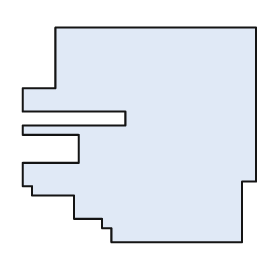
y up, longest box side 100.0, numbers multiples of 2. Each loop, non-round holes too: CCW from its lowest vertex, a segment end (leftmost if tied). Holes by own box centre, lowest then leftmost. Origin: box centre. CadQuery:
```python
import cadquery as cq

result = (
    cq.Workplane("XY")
    .moveTo(-12.0, -46.0)
    .lineTo(44.0, -46.0)
    .lineTo(44.0, -20.0)
    .lineTo(50.0, -20.0)
    .lineTo(50.0, 46.0)
    .lineTo(-36.0, 46.0)
    .lineTo(-36.0, 20.0)
    .lineTo(-50.0, 20.0)
    .lineTo(-50.0, 10.0)
    .lineTo(-6.0, 10.0)
    .lineTo(-6.0, 4.0)
    .lineTo(-50.0, 4.0)
    .lineTo(-50.0, 0.0)
    .lineTo(-26.0, 0.0)
    .lineTo(-26.0, -12.0)
    .lineTo(-50.0, -12.0)
    .lineTo(-50.0, -22.0)
    .lineTo(-46.0, -22.0)
    .lineTo(-46.0, -26.0)
    .lineTo(-28.0, -26.0)
    .lineTo(-28.0, -36.0)
    .lineTo(-16.0, -36.0)
    .lineTo(-16.0, -40.0)
    .lineTo(-12.0, -40.0)
    .close()
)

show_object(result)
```